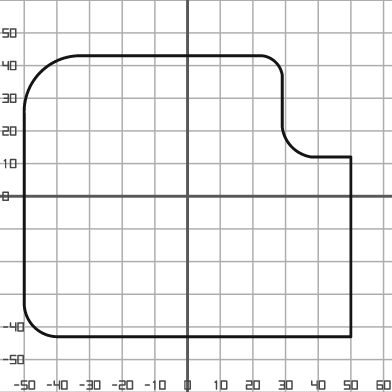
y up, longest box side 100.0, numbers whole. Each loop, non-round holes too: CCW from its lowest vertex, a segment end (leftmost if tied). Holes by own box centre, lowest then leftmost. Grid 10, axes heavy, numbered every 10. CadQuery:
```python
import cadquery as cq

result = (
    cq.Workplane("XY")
    .moveTo(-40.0, -43.0)
    .lineTo(50.0, -43.0)
    .lineTo(50.0, 12.0)
    .lineTo(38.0, 12.0)
    .threePointArc((32.0, 15.0), (29.0, 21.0))
    .lineTo(29.0, 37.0)
    .threePointArc((27.0, 41.0), (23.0, 43.0))
    .lineTo(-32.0, 43.0)
    .threePointArc((-45.0, 38.0), (-50.0, 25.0))
    .lineTo(-50.0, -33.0)
    .threePointArc((-47.0, -40.0), (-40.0, -43.0))
    .close()
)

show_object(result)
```